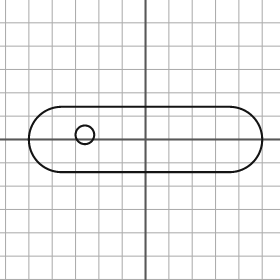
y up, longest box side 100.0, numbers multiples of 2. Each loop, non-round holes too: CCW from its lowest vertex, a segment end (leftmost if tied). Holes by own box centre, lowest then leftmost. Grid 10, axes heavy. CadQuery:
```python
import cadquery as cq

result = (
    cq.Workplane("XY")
    .moveTo(-36.0, -14.0)
    .lineTo(36.0, -14.0)
    .threePointArc((50.0, 0.0), (36.0, 14.0))
    .lineTo(-36.0, 14.0)
    .threePointArc((-50.0, 0.0), (-36.0, -14.0))
    .close()
    .moveTo(-26.0, 2.0)
    .circle(4.0)
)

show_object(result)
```